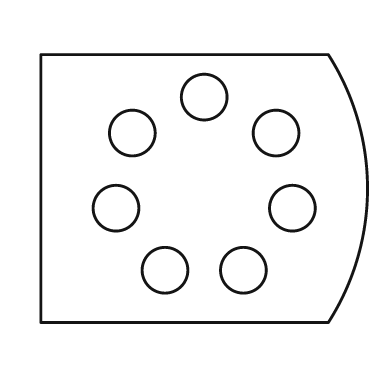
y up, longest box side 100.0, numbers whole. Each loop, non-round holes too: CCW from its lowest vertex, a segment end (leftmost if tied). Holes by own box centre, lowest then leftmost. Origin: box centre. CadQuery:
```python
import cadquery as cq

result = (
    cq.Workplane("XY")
    .moveTo(-50.0, -41.0)
    .lineTo(38.0, -41.0)
    .threePointArc((50.0, 0.0), (38.0, 41.0))
    .lineTo(-50.0, 41.0)
    .close()
    .moveTo(-12.0, -25.0)
    .circle(7.0)
    .moveTo(12.0, -25.0)
    .circle(7.0)
    .moveTo(-27.0, -6.0)
    .circle(7.0)
    .moveTo(27.0, -6.0)
    .circle(7.0)
    .moveTo(-22.0, 17.0)
    .circle(7.0)
    .moveTo(22.0, 17.0)
    .circle(7.0)
    .moveTo(0.0, 28.0)
    .circle(7.0)
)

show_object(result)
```